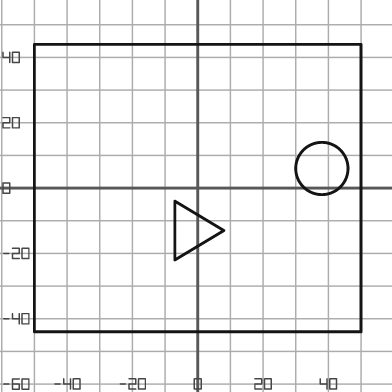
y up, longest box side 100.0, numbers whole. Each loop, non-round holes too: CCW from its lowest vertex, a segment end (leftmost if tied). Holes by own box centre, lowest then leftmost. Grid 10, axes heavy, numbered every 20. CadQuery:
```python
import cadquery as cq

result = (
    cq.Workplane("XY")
    .moveTo(-50.0, -44.0)
    .lineTo(50.0, -44.0)
    .lineTo(50.0, 44.0)
    .lineTo(-50.0, 44.0)
    .close()
    .moveTo(-7.0, -22.0)
    .lineTo(8.0, -13.0)
    .lineTo(-7.0, -4.0)
    .close()
    .moveTo(38.0, 6.0)
    .circle(8.0)
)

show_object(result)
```